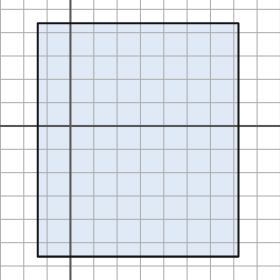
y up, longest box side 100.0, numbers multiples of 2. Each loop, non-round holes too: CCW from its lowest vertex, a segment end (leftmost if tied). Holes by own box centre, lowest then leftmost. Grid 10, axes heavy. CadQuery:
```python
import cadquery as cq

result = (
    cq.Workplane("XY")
    .moveTo(-14.0, -56.0)
    .lineTo(72.0, -56.0)
    .lineTo(72.0, 44.0)
    .lineTo(-14.0, 44.0)
    .close()
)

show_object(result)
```